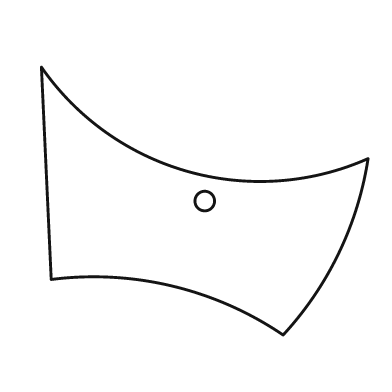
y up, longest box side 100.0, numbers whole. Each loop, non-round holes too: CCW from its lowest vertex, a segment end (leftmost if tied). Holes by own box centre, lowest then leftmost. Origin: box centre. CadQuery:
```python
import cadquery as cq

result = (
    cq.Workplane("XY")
    .moveTo(24.0, -41.0)
    .threePointArc((41.0, -16.0), (50.0, 13.0))
    .threePointArc((-5.0, 9.0), (-50.0, 41.0))
    .lineTo(-47.0, -24.0)
    .threePointArc((-10.0, -26.0), (24.0, -41.0))
    .close()
    .moveTo(0.0, 0.0)
    .circle(3.0)
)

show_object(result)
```